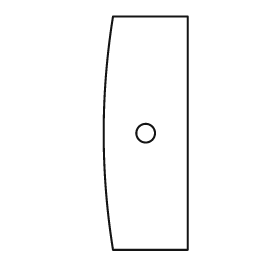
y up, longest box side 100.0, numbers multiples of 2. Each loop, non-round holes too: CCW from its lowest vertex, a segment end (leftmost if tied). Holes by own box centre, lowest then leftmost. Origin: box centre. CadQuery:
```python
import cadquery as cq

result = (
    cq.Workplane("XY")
    .moveTo(-14.0, -50.0)
    .lineTo(18.0, -50.0)
    .lineTo(18.0, 50.0)
    .lineTo(-14.0, 50.0)
    .threePointArc((-18.0, 0.0), (-14.0, -50.0))
    .close()
    .moveTo(0.0, 0.0)
    .circle(4.0)
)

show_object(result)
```